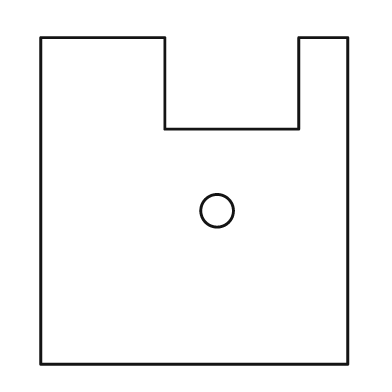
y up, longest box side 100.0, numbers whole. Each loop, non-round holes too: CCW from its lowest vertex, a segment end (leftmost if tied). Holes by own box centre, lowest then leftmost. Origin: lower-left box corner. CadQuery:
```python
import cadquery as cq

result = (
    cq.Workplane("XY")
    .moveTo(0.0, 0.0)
    .lineTo(94.0, 0.0)
    .lineTo(94.0, 100.0)
    .lineTo(79.0, 100.0)
    .lineTo(79.0, 72.0)
    .lineTo(38.0, 72.0)
    .lineTo(38.0, 100.0)
    .lineTo(0.0, 100.0)
    .close()
    .moveTo(54.0, 47.0)
    .circle(5.0)
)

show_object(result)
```